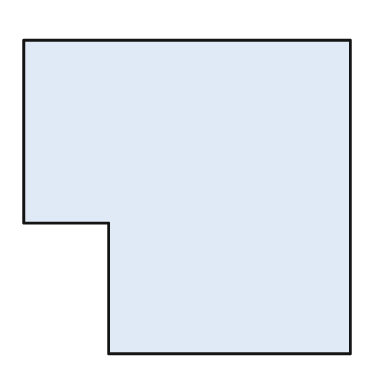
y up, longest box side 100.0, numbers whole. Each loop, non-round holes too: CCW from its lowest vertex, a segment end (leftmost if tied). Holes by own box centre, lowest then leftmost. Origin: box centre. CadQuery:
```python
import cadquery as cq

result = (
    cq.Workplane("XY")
    .moveTo(-24.0, -48.0)
    .lineTo(50.0, -48.0)
    .lineTo(50.0, 48.0)
    .lineTo(-50.0, 48.0)
    .lineTo(-50.0, -8.0)
    .lineTo(-24.0, -8.0)
    .close()
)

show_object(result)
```